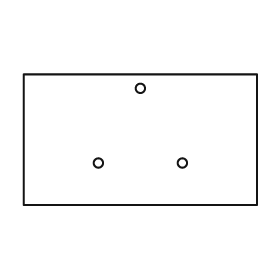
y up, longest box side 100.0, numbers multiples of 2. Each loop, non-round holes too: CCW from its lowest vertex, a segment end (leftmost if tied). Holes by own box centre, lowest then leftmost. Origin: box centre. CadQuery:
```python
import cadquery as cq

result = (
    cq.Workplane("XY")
    .moveTo(-50.0, -28.0)
    .lineTo(50.0, -28.0)
    .lineTo(50.0, 28.0)
    .lineTo(-50.0, 28.0)
    .close()
    .moveTo(-18.0, -10.0)
    .circle(2.0)
    .moveTo(18.0, -10.0)
    .circle(2.0)
    .moveTo(0.0, 22.0)
    .circle(2.0)
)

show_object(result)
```